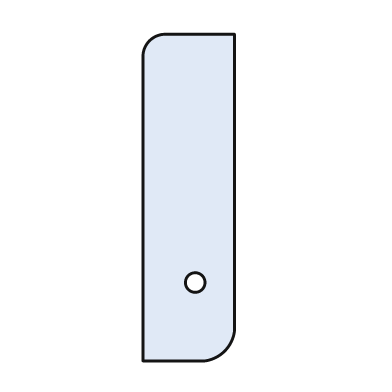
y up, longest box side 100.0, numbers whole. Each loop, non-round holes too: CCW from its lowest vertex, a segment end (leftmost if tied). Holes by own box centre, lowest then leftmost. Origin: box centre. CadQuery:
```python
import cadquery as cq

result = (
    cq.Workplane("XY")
    .moveTo(-14.0, -50.0)
    .lineTo(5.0, -50.0)
    .threePointArc((11.0, -47.0), (14.0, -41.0))
    .lineTo(14.0, 50.0)
    .lineTo(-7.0, 50.0)
    .threePointArc((-12.0, 48.0), (-14.0, 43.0))
    .close()
    .moveTo(2.0, -26.0)
    .circle(3.0)
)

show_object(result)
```